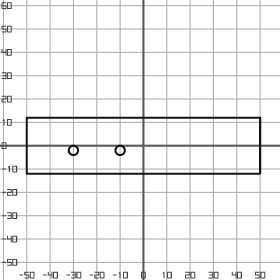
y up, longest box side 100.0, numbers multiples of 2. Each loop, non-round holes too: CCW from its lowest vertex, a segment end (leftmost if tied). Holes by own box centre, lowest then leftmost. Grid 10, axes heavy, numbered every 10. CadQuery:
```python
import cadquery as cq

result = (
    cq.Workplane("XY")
    .moveTo(-50.0, -12.0)
    .lineTo(50.0, -12.0)
    .lineTo(50.0, 12.0)
    .lineTo(-50.0, 12.0)
    .close()
    .moveTo(-30.0, -2.0)
    .circle(2.0)
    .moveTo(-10.0, -2.0)
    .circle(2.0)
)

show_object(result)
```